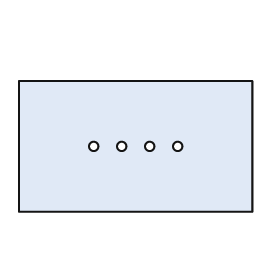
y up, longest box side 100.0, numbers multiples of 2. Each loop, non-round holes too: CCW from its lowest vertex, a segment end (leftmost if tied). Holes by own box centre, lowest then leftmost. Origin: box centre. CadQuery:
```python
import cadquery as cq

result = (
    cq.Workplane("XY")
    .moveTo(-50.0, -28.0)
    .lineTo(50.0, -28.0)
    .lineTo(50.0, 28.0)
    .lineTo(-50.0, 28.0)
    .close()
    .moveTo(-18.0, 0.0)
    .circle(2.0)
    .moveTo(-6.0, 0.0)
    .circle(2.0)
    .moveTo(6.0, 0.0)
    .circle(2.0)
    .moveTo(18.0, 0.0)
    .circle(2.0)
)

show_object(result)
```